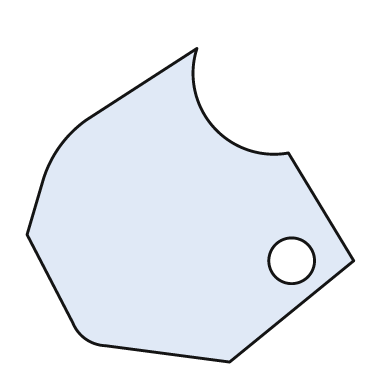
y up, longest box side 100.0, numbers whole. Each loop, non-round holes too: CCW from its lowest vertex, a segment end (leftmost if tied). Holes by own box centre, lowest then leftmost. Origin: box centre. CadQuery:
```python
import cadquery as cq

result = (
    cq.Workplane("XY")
    .moveTo(12.0, -48.0)
    .lineTo(50.0, -17.0)
    .lineTo(30.0, 16.0)
    .threePointArc((7.0, 24.0), (2.0, 48.0))
    .lineTo(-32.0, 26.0)
    .threePointArc((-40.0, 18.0), (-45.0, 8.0))
    .lineTo(-50.0, -9.0)
    .lineTo(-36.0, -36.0)
    .threePointArc((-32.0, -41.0), (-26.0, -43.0))
    .close()
    .moveTo(31.0, -17.0)
    .circle(7.0)
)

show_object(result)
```